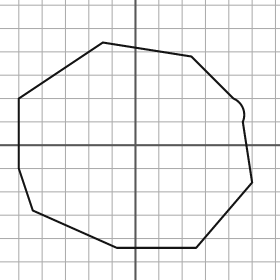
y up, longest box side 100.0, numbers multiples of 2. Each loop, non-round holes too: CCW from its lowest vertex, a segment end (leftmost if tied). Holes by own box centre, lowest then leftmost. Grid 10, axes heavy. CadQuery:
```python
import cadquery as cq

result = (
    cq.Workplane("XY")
    .moveTo(-8.0, -44.0)
    .lineTo(26.0, -44.0)
    .lineTo(50.0, -16.0)
    .lineTo(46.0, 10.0)
    .threePointArc((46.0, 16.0), (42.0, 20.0))
    .lineTo(24.0, 38.0)
    .lineTo(-14.0, 44.0)
    .lineTo(-50.0, 20.0)
    .lineTo(-50.0, -10.0)
    .lineTo(-44.0, -28.0)
    .close()
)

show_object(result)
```